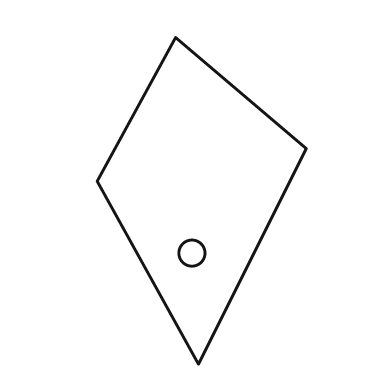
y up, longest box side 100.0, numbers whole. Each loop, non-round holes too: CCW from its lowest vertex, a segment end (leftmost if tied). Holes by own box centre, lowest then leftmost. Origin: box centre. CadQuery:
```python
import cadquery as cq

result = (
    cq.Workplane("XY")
    .moveTo(-1.0, -50.0)
    .lineTo(32.0, 16.0)
    .lineTo(-8.0, 50.0)
    .lineTo(-32.0, 6.0)
    .close()
    .moveTo(-3.0, -16.0)
    .circle(4.0)
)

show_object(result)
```